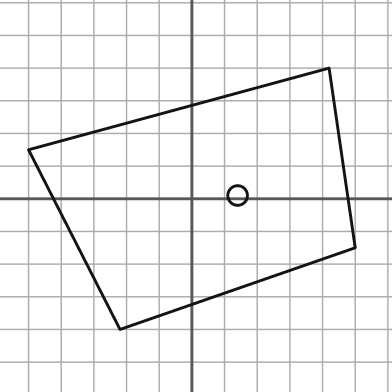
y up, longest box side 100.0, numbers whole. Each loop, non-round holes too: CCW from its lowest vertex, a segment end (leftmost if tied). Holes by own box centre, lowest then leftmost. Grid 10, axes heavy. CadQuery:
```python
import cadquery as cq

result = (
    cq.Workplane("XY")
    .moveTo(-22.0, -40.0)
    .lineTo(50.0, -15.0)
    .lineTo(42.0, 40.0)
    .lineTo(-50.0, 15.0)
    .close()
    .moveTo(14.0, 1.0)
    .circle(3.0)
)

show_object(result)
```